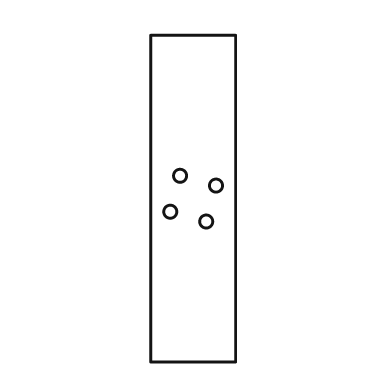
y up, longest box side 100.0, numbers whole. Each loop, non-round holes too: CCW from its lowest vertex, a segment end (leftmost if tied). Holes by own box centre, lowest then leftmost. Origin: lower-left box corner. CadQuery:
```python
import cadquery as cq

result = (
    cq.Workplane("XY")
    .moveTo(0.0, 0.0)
    .lineTo(26.0, 0.0)
    .lineTo(26.0, 100.0)
    .lineTo(0.0, 100.0)
    .close()
    .moveTo(17.0, 43.0)
    .circle(2.0)
    .moveTo(6.0, 46.0)
    .circle(2.0)
    .moveTo(20.0, 54.0)
    .circle(2.0)
    .moveTo(9.0, 57.0)
    .circle(2.0)
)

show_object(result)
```